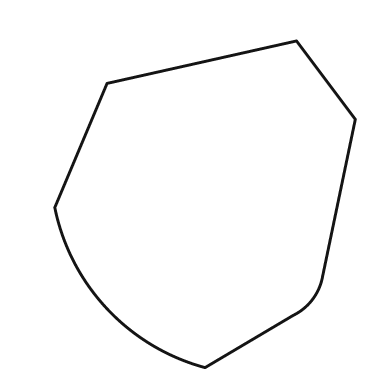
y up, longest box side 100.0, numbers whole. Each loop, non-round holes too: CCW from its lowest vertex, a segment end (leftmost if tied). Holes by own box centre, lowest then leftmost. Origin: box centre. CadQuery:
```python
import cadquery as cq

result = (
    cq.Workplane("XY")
    .moveTo(0.0, -50.0)
    .lineTo(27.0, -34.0)
    .threePointArc((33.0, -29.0), (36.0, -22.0))
    .lineTo(46.0, 26.0)
    .lineTo(28.0, 50.0)
    .lineTo(-30.0, 37.0)
    .lineTo(-46.0, -1.0)
    .threePointArc((-30.0, -32.0), (0.0, -50.0))
    .close()
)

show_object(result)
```